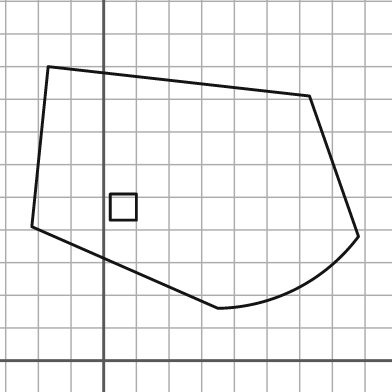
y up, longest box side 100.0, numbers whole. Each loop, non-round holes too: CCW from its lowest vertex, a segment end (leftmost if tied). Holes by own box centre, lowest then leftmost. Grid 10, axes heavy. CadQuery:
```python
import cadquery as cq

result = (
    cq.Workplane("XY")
    .moveTo(35.0, 16.0)
    .threePointArc((59.0, 22.0), (78.0, 38.0))
    .lineTo(63.0, 81.0)
    .lineTo(-17.0, 90.0)
    .lineTo(-22.0, 41.0)
    .close()
    .moveTo(2.0, 43.0)
    .lineTo(10.0, 43.0)
    .lineTo(10.0, 51.0)
    .lineTo(2.0, 51.0)
    .close()
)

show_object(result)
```